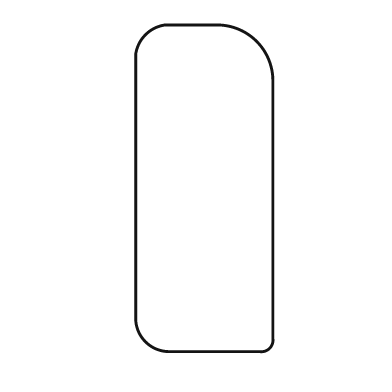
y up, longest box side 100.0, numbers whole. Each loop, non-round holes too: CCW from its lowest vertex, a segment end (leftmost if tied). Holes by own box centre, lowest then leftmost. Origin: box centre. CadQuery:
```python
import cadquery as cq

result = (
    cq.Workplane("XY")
    .moveTo(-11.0, -50.0)
    .lineTo(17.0, -50.0)
    .threePointArc((20.0, -49.0), (21.0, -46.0))
    .lineTo(21.0, 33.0)
    .threePointArc((16.0, 45.0), (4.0, 50.0))
    .lineTo(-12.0, 50.0)
    .threePointArc((-18.0, 47.0), (-21.0, 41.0))
    .lineTo(-21.0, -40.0)
    .threePointArc((-18.0, -47.0), (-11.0, -50.0))
    .close()
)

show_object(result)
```